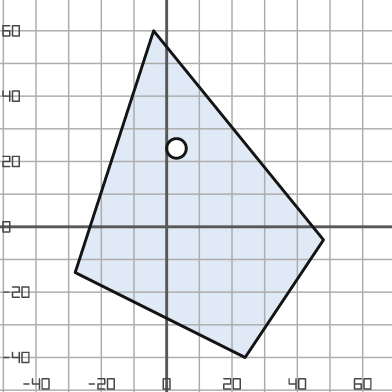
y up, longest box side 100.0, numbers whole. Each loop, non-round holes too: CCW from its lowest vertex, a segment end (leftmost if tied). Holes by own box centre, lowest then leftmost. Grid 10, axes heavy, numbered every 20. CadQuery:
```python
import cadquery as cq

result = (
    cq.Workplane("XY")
    .moveTo(24.0, -40.0)
    .lineTo(48.0, -4.0)
    .lineTo(-4.0, 60.0)
    .lineTo(-28.0, -14.0)
    .close()
    .moveTo(3.0, 24.0)
    .circle(3.0)
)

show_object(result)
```